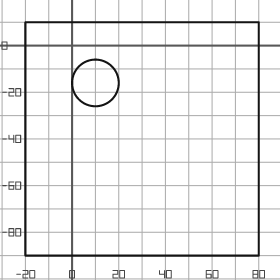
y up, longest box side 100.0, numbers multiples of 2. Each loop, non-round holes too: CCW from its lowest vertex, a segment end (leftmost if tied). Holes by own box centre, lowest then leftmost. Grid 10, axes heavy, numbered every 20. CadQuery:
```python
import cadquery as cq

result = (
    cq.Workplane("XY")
    .moveTo(-20.0, -90.0)
    .lineTo(80.0, -90.0)
    .lineTo(80.0, 10.0)
    .lineTo(-20.0, 10.0)
    .close()
    .moveTo(10.0, -16.0)
    .circle(10.0)
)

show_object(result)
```